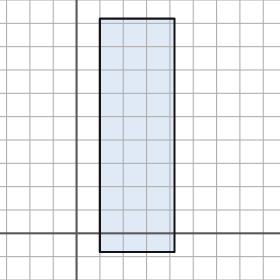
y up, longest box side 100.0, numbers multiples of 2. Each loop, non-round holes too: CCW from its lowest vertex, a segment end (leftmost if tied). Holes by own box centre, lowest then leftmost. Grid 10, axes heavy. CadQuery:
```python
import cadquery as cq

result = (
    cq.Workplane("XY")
    .moveTo(10.0, -8.0)
    .lineTo(42.0, -8.0)
    .lineTo(42.0, 92.0)
    .lineTo(10.0, 92.0)
    .close()
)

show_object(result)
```